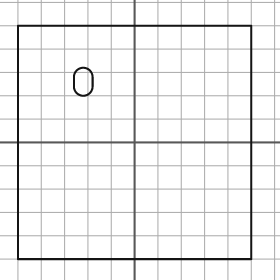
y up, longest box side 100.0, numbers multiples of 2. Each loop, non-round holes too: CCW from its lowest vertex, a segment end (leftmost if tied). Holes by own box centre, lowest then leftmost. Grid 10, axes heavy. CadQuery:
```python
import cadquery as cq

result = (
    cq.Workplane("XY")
    .moveTo(-50.0, -50.0)
    .lineTo(50.0, -50.0)
    .lineTo(50.0, 50.0)
    .lineTo(-50.0, 50.0)
    .close()
    .moveTo(-26.0, 24.0)
    .threePointArc((-22.0, 20.0), (-18.0, 24.0))
    .lineTo(-18.0, 28.0)
    .threePointArc((-22.0, 32.0), (-26.0, 28.0))
    .close()
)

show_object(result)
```